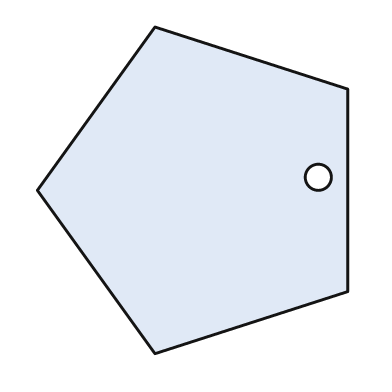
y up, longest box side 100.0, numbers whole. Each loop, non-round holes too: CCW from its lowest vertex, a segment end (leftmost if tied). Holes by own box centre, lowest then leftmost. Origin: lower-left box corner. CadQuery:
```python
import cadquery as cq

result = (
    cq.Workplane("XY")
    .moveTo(36.0, 0.0)
    .lineTo(95.0, 19.0)
    .lineTo(95.0, 81.0)
    .lineTo(36.0, 100.0)
    .lineTo(0.0, 50.0)
    .close()
    .moveTo(86.0, 54.0)
    .circle(4.0)
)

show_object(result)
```